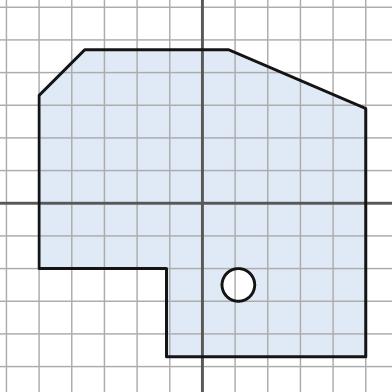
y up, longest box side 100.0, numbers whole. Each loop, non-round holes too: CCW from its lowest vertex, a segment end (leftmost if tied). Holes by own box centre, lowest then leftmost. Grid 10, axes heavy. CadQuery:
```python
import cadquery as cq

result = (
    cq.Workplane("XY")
    .moveTo(-11.0, -47.0)
    .lineTo(50.0, -47.0)
    .lineTo(50.0, 29.0)
    .lineTo(8.0, 47.0)
    .lineTo(-36.0, 47.0)
    .lineTo(-50.0, 33.0)
    .lineTo(-50.0, -20.0)
    .lineTo(-11.0, -20.0)
    .close()
    .moveTo(11.0, -25.0)
    .circle(5.0)
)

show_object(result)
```